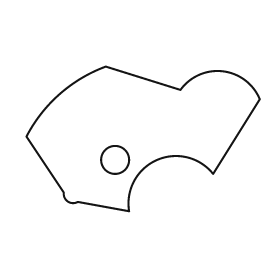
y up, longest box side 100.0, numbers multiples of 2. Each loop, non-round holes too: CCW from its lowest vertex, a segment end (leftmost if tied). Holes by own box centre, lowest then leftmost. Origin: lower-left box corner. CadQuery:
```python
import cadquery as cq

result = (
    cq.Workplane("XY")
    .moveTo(44.0, 0.0)
    .threePointArc((56.0, 22.0), (80.0, 16.0))
    .lineTo(100.0, 48.0)
    .threePointArc((84.0, 60.0), (66.0, 52.0))
    .lineTo(34.0, 62.0)
    .threePointArc((14.0, 50.0), (0.0, 32.0))
    .lineTo(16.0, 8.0)
    .threePointArc((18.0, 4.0), (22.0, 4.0))
    .close()
    .moveTo(38.0, 22.0)
    .circle(6.0)
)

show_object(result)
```